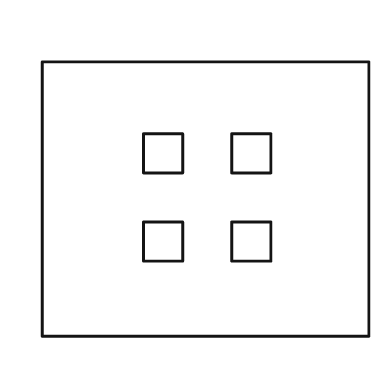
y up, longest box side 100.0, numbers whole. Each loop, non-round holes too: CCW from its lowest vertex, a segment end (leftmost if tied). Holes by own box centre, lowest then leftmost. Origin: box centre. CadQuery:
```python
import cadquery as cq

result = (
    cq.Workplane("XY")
    .moveTo(-50.0, -42.0)
    .lineTo(50.0, -42.0)
    .lineTo(50.0, 42.0)
    .lineTo(-50.0, 42.0)
    .close()
    .moveTo(-19.0, -19.0)
    .lineTo(-7.0, -19.0)
    .lineTo(-7.0, -7.0)
    .lineTo(-19.0, -7.0)
    .close()
    .moveTo(8.0, -19.0)
    .lineTo(20.0, -19.0)
    .lineTo(20.0, -7.0)
    .lineTo(8.0, -7.0)
    .close()
    .moveTo(-19.0, 8.0)
    .lineTo(-7.0, 8.0)
    .lineTo(-7.0, 20.0)
    .lineTo(-19.0, 20.0)
    .close()
    .moveTo(8.0, 8.0)
    .lineTo(20.0, 8.0)
    .lineTo(20.0, 20.0)
    .lineTo(8.0, 20.0)
    .close()
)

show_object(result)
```